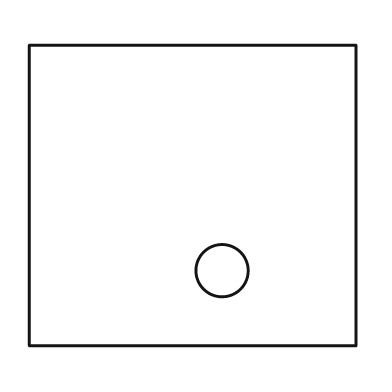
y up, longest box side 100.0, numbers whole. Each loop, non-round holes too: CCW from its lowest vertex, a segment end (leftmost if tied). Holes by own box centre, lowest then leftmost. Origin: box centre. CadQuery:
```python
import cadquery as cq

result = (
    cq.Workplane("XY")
    .moveTo(-50.0, -46.0)
    .lineTo(50.0, -46.0)
    .lineTo(50.0, 46.0)
    .lineTo(-50.0, 46.0)
    .close()
    .moveTo(9.0, -23.0)
    .circle(8.0)
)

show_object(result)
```